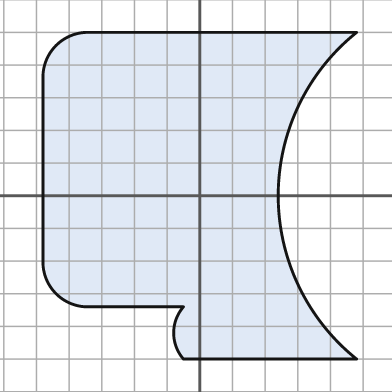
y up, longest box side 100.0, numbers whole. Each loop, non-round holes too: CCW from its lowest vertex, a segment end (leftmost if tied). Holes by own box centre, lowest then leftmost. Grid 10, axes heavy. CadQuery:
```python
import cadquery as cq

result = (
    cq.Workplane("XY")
    .moveTo(-5.0, -50.0)
    .lineTo(48.0, -50.0)
    .threePointArc((24.0, 0.0), (48.0, 50.0))
    .lineTo(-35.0, 50.0)
    .threePointArc((-44.0, 46.0), (-48.0, 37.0))
    .lineTo(-48.0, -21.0)
    .threePointArc((-44.0, -30.0), (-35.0, -34.0))
    .lineTo(-5.0, -34.0)
    .threePointArc((-8.0, -42.0), (-5.0, -50.0))
    .close()
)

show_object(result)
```